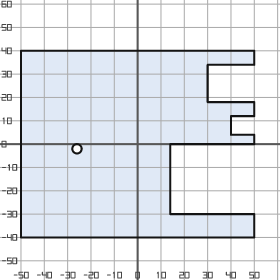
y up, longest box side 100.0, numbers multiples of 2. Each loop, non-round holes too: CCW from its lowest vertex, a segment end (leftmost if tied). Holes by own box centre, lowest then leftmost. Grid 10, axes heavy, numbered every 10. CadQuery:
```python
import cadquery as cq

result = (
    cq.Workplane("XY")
    .moveTo(-50.0, -40.0)
    .lineTo(50.0, -40.0)
    .lineTo(50.0, -30.0)
    .lineTo(14.0, -30.0)
    .lineTo(14.0, 0.0)
    .lineTo(50.0, 0.0)
    .lineTo(50.0, 4.0)
    .lineTo(40.0, 4.0)
    .lineTo(40.0, 12.0)
    .lineTo(50.0, 12.0)
    .lineTo(50.0, 18.0)
    .lineTo(30.0, 18.0)
    .lineTo(30.0, 34.0)
    .lineTo(50.0, 34.0)
    .lineTo(50.0, 40.0)
    .lineTo(-50.0, 40.0)
    .close()
    .moveTo(-26.0, -2.0)
    .circle(2.0)
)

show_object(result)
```